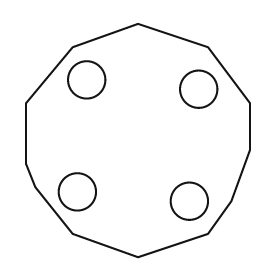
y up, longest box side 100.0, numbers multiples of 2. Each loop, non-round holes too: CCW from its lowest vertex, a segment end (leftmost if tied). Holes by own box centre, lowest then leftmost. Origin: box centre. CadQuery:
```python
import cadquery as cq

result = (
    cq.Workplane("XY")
    .moveTo(0.0, -50.0)
    .lineTo(30.0, -40.0)
    .lineTo(40.0, -26.0)
    .lineTo(48.0, -4.0)
    .lineTo(48.0, 16.0)
    .lineTo(30.0, 40.0)
    .lineTo(0.0, 50.0)
    .lineTo(-28.0, 40.0)
    .lineTo(-48.0, 16.0)
    .lineTo(-48.0, -10.0)
    .lineTo(-44.0, -20.0)
    .lineTo(-28.0, -40.0)
    .close()
    .moveTo(22.0, -26.0)
    .circle(8.0)
    .moveTo(-26.0, -22.0)
    .circle(8.0)
    .moveTo(26.0, 22.0)
    .circle(8.0)
    .moveTo(-22.0, 26.0)
    .circle(8.0)
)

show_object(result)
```